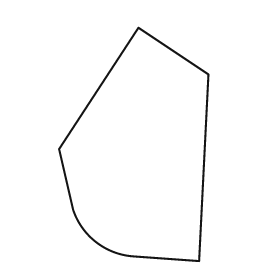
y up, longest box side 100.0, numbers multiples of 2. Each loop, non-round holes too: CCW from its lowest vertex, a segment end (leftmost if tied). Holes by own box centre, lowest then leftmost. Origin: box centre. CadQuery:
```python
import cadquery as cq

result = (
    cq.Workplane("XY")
    .moveTo(28.0, -50.0)
    .lineTo(32.0, 30.0)
    .lineTo(2.0, 50.0)
    .lineTo(-32.0, -2.0)
    .lineTo(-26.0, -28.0)
    .threePointArc((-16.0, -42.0), (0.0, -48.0))
    .close()
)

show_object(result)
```